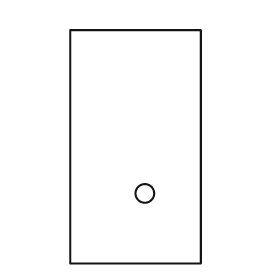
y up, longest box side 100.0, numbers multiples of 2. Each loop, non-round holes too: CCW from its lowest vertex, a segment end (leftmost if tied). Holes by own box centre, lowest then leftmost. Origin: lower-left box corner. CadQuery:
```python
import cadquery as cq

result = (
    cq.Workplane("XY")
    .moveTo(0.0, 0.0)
    .lineTo(56.0, 0.0)
    .lineTo(56.0, 100.0)
    .lineTo(0.0, 100.0)
    .close()
    .moveTo(32.0, 30.0)
    .circle(4.0)
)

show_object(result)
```